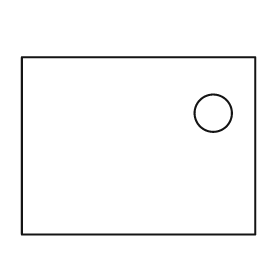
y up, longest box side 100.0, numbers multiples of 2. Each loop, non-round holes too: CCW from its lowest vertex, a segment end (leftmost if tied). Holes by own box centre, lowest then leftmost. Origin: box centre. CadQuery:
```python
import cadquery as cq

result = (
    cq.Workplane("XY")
    .moveTo(-50.0, -38.0)
    .lineTo(50.0, -38.0)
    .lineTo(50.0, 38.0)
    .lineTo(-50.0, 38.0)
    .close()
    .moveTo(32.0, 14.0)
    .circle(8.0)
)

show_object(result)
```